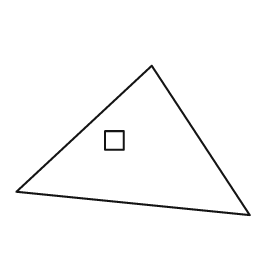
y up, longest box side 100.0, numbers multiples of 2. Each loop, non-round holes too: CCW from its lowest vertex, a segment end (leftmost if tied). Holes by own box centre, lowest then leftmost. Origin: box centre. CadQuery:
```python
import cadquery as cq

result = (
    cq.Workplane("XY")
    .moveTo(50.0, -32.0)
    .lineTo(8.0, 32.0)
    .lineTo(-50.0, -22.0)
    .close()
    .moveTo(-12.0, -4.0)
    .lineTo(-4.0, -4.0)
    .lineTo(-4.0, 4.0)
    .lineTo(-12.0, 4.0)
    .close()
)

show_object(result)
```